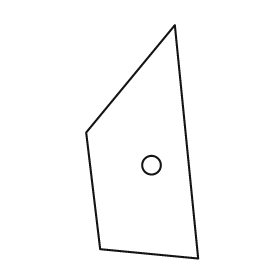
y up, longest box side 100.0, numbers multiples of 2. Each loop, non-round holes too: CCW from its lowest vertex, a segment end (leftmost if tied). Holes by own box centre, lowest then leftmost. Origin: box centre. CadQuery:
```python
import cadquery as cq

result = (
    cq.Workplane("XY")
    .moveTo(24.0, -50.0)
    .lineTo(14.0, 50.0)
    .lineTo(-24.0, 4.0)
    .lineTo(-18.0, -46.0)
    .close()
    .moveTo(4.0, -10.0)
    .circle(4.0)
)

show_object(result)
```